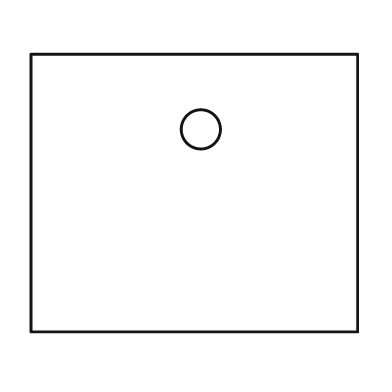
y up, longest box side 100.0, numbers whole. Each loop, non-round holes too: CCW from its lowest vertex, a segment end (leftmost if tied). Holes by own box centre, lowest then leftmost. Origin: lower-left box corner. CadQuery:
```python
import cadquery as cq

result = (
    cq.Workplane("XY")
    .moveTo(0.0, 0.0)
    .lineTo(100.0, 0.0)
    .lineTo(100.0, 85.0)
    .lineTo(0.0, 85.0)
    .close()
    .moveTo(52.0, 62.0)
    .circle(6.0)
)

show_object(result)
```